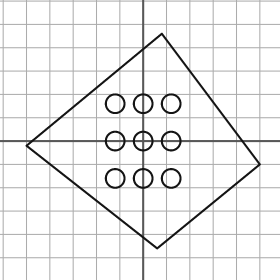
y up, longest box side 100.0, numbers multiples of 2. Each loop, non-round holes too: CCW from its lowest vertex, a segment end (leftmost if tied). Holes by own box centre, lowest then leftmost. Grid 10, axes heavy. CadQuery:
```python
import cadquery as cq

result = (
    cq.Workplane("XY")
    .moveTo(6.0, -46.0)
    .lineTo(50.0, -10.0)
    .lineTo(8.0, 46.0)
    .lineTo(-50.0, -2.0)
    .close()
    .moveTo(-12.0, -16.0)
    .circle(4.0)
    .moveTo(0.0, -16.0)
    .circle(4.0)
    .moveTo(12.0, -16.0)
    .circle(4.0)
    .moveTo(-12.0, 0.0)
    .circle(4.0)
    .moveTo(0.0, 0.0)
    .circle(4.0)
    .moveTo(12.0, 0.0)
    .circle(4.0)
    .moveTo(-12.0, 16.0)
    .circle(4.0)
    .moveTo(0.0, 16.0)
    .circle(4.0)
    .moveTo(12.0, 16.0)
    .circle(4.0)
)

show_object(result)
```